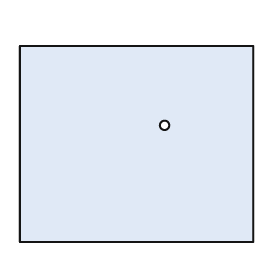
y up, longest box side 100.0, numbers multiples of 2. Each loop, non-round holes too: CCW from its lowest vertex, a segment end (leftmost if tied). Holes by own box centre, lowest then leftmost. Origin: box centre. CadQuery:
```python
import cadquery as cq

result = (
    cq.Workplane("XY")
    .moveTo(-50.0, -42.0)
    .lineTo(50.0, -42.0)
    .lineTo(50.0, 42.0)
    .lineTo(-50.0, 42.0)
    .close()
    .moveTo(12.0, 8.0)
    .circle(2.0)
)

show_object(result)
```